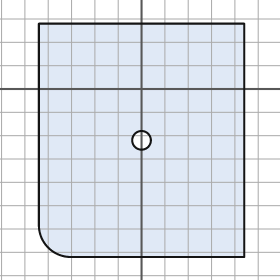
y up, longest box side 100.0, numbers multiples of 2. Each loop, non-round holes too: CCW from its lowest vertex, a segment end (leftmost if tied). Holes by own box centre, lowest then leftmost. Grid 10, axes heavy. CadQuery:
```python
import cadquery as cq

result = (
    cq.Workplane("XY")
    .moveTo(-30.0, -72.0)
    .lineTo(44.0, -72.0)
    .lineTo(44.0, 28.0)
    .lineTo(-44.0, 28.0)
    .lineTo(-44.0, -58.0)
    .threePointArc((-40.0, -68.0), (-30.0, -72.0))
    .close()
    .moveTo(0.0, -22.0)
    .circle(4.0)
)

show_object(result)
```